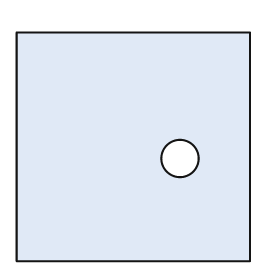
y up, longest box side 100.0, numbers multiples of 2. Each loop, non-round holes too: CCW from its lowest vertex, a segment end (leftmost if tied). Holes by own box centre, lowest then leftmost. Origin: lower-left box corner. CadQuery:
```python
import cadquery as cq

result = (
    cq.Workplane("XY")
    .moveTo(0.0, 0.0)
    .lineTo(100.0, 0.0)
    .lineTo(100.0, 98.0)
    .lineTo(0.0, 98.0)
    .close()
    .moveTo(70.0, 44.0)
    .circle(8.0)
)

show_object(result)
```